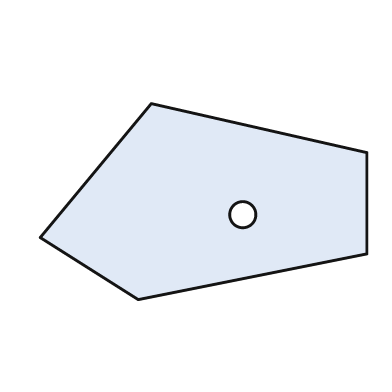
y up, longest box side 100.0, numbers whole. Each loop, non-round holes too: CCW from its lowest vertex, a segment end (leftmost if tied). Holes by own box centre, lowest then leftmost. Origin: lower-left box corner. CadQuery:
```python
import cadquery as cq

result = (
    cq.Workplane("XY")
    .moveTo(30.0, 0.0)
    .lineTo(100.0, 14.0)
    .lineTo(100.0, 45.0)
    .lineTo(34.0, 60.0)
    .lineTo(0.0, 19.0)
    .close()
    .moveTo(62.0, 26.0)
    .circle(4.0)
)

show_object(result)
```